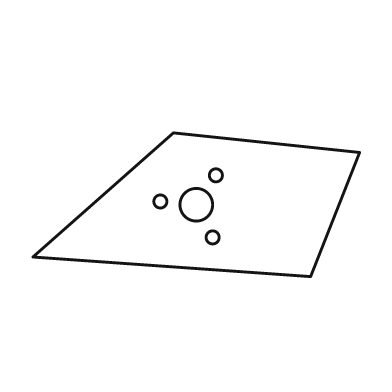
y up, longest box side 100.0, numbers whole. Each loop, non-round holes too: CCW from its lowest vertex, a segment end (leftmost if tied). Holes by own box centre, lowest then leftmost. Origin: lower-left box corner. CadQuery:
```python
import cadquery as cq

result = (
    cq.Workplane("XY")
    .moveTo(85.0, 0.0)
    .lineTo(100.0, 38.0)
    .lineTo(43.0, 44.0)
    .lineTo(0.0, 6.0)
    .close()
    .moveTo(55.0, 12.0)
    .circle(2.0)
    .moveTo(50.0, 22.0)
    .circle(5.0)
    .moveTo(39.0, 23.0)
    .circle(2.0)
    .moveTo(56.0, 31.0)
    .circle(2.0)
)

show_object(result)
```